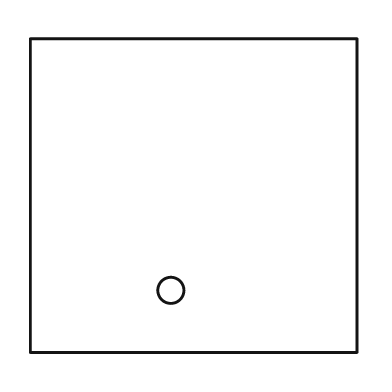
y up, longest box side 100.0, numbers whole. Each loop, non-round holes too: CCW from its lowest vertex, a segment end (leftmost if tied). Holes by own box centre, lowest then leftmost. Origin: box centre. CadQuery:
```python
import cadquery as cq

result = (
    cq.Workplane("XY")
    .moveTo(-50.0, -48.0)
    .lineTo(50.0, -48.0)
    .lineTo(50.0, 48.0)
    .lineTo(-50.0, 48.0)
    .close()
    .moveTo(-7.0, -29.0)
    .circle(4.0)
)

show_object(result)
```